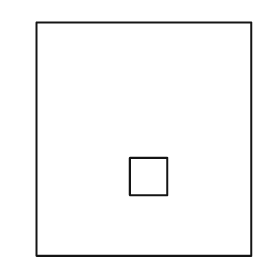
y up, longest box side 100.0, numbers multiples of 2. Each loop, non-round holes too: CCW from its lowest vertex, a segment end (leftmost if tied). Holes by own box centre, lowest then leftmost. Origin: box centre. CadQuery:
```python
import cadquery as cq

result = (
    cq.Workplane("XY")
    .moveTo(-46.0, -50.0)
    .lineTo(46.0, -50.0)
    .lineTo(46.0, 50.0)
    .lineTo(-46.0, 50.0)
    .close()
    .moveTo(-6.0, -24.0)
    .lineTo(10.0, -24.0)
    .lineTo(10.0, -8.0)
    .lineTo(-6.0, -8.0)
    .close()
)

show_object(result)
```